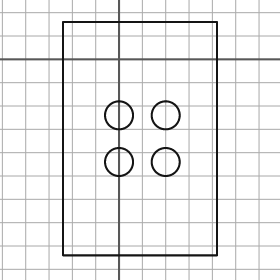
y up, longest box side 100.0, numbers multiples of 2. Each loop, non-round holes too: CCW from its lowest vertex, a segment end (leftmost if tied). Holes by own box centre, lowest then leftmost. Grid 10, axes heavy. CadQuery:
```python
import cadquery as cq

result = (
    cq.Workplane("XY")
    .moveTo(-24.0, -84.0)
    .lineTo(42.0, -84.0)
    .lineTo(42.0, 16.0)
    .lineTo(-24.0, 16.0)
    .close()
    .moveTo(0.0, -44.0)
    .circle(6.0)
    .moveTo(20.0, -44.0)
    .circle(6.0)
    .moveTo(0.0, -24.0)
    .circle(6.0)
    .moveTo(20.0, -24.0)
    .circle(6.0)
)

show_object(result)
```